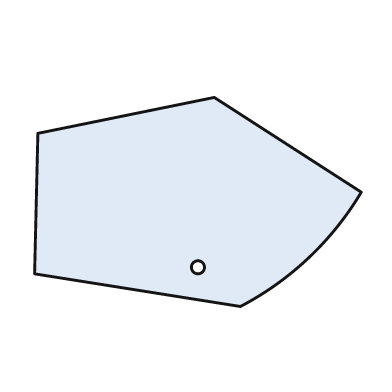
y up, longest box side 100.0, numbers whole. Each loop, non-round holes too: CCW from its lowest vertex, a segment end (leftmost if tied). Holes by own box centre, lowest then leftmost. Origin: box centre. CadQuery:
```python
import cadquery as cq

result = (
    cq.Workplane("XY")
    .moveTo(13.0, -32.0)
    .threePointArc((34.0, -17.0), (50.0, 3.0))
    .lineTo(5.0, 32.0)
    .lineTo(-49.0, 21.0)
    .lineTo(-50.0, -22.0)
    .close()
    .moveTo(0.0, -20.0)
    .circle(2.0)
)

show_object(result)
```